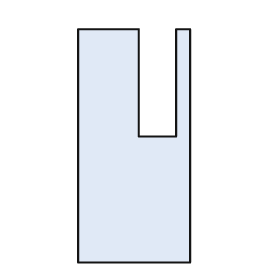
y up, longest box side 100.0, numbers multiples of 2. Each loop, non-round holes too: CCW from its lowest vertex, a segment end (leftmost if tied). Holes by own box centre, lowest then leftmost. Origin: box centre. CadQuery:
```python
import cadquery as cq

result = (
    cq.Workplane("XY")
    .moveTo(-24.0, -50.0)
    .lineTo(24.0, -50.0)
    .lineTo(24.0, 50.0)
    .lineTo(18.0, 50.0)
    .lineTo(18.0, 4.0)
    .lineTo(2.0, 4.0)
    .lineTo(2.0, 50.0)
    .lineTo(-24.0, 50.0)
    .close()
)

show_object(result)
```